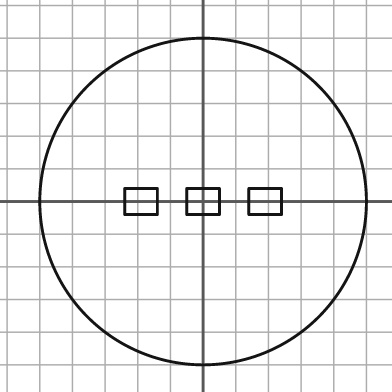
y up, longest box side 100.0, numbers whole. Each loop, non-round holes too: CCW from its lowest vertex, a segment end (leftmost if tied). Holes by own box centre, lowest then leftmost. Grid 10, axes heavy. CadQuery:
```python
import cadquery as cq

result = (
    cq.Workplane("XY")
    .moveTo(0.0, 0.0)
    .circle(50.0)
    .moveTo(-24.0, -4.0)
    .lineTo(-14.0, -4.0)
    .lineTo(-14.0, 4.0)
    .lineTo(-24.0, 4.0)
    .close()
    .moveTo(-5.0, -4.0)
    .lineTo(5.0, -4.0)
    .lineTo(5.0, 4.0)
    .lineTo(-5.0, 4.0)
    .close()
    .moveTo(14.0, -4.0)
    .lineTo(24.0, -4.0)
    .lineTo(24.0, 4.0)
    .lineTo(14.0, 4.0)
    .close()
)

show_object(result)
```